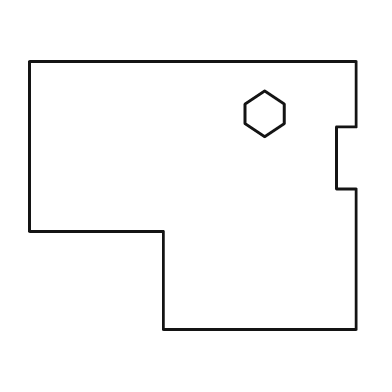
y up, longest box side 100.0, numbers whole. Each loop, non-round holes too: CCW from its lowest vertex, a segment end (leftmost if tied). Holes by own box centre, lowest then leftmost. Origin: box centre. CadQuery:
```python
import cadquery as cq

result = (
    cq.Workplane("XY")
    .moveTo(-9.0, -41.0)
    .lineTo(50.0, -41.0)
    .lineTo(50.0, 2.0)
    .lineTo(44.0, 2.0)
    .lineTo(44.0, 21.0)
    .lineTo(50.0, 21.0)
    .lineTo(50.0, 41.0)
    .lineTo(-50.0, 41.0)
    .lineTo(-50.0, -11.0)
    .lineTo(-9.0, -11.0)
    .close()
    .moveTo(22.0, 18.0)
    .lineTo(28.0, 22.0)
    .lineTo(28.0, 28.0)
    .lineTo(22.0, 32.0)
    .lineTo(16.0, 28.0)
    .lineTo(16.0, 22.0)
    .close()
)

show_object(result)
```